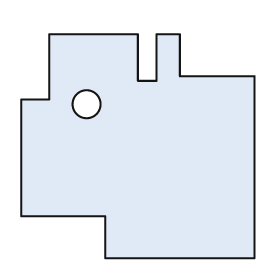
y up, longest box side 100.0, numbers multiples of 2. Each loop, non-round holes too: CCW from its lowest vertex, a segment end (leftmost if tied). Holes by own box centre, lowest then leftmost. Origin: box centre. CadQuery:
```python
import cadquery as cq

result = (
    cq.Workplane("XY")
    .moveTo(-14.0, -48.0)
    .lineTo(50.0, -48.0)
    .lineTo(50.0, 30.0)
    .lineTo(18.0, 30.0)
    .lineTo(18.0, 48.0)
    .lineTo(8.0, 48.0)
    .lineTo(8.0, 28.0)
    .lineTo(0.0, 28.0)
    .lineTo(0.0, 48.0)
    .lineTo(-38.0, 48.0)
    .lineTo(-38.0, 20.0)
    .lineTo(-50.0, 20.0)
    .lineTo(-50.0, -30.0)
    .lineTo(-14.0, -30.0)
    .close()
    .moveTo(-22.0, 18.0)
    .circle(6.0)
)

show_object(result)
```